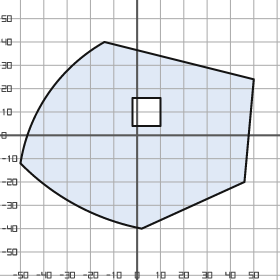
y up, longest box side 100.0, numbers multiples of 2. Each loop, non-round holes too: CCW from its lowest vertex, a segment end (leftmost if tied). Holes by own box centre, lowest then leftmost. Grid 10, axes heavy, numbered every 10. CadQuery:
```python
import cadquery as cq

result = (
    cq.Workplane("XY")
    .moveTo(2.0, -40.0)
    .lineTo(46.0, -20.0)
    .lineTo(50.0, 24.0)
    .lineTo(-14.0, 40.0)
    .threePointArc((-38.0, 18.0), (-50.0, -12.0))
    .threePointArc((-26.0, -30.0), (2.0, -40.0))
    .close()
    .moveTo(-2.0, 4.0)
    .lineTo(10.0, 4.0)
    .lineTo(10.0, 16.0)
    .lineTo(-2.0, 16.0)
    .close()
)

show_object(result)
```